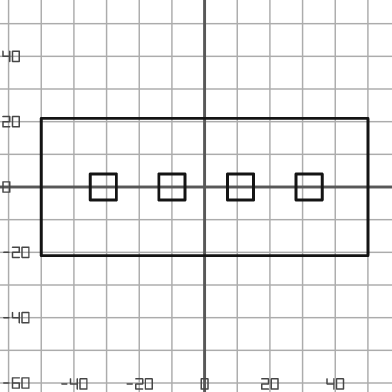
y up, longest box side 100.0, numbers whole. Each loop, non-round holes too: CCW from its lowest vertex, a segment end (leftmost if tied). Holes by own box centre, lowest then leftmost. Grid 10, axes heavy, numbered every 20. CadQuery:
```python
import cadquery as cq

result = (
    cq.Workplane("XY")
    .moveTo(-50.0, -21.0)
    .lineTo(50.0, -21.0)
    .lineTo(50.0, 21.0)
    .lineTo(-50.0, 21.0)
    .close()
    .moveTo(-35.0, -4.0)
    .lineTo(-27.0, -4.0)
    .lineTo(-27.0, 4.0)
    .lineTo(-35.0, 4.0)
    .close()
    .moveTo(-14.0, -4.0)
    .lineTo(-6.0, -4.0)
    .lineTo(-6.0, 4.0)
    .lineTo(-14.0, 4.0)
    .close()
    .moveTo(7.0, -4.0)
    .lineTo(15.0, -4.0)
    .lineTo(15.0, 4.0)
    .lineTo(7.0, 4.0)
    .close()
    .moveTo(28.0, -4.0)
    .lineTo(36.0, -4.0)
    .lineTo(36.0, 4.0)
    .lineTo(28.0, 4.0)
    .close()
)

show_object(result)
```